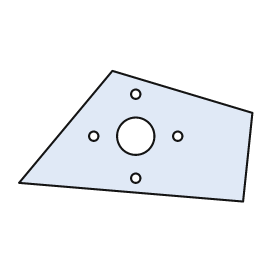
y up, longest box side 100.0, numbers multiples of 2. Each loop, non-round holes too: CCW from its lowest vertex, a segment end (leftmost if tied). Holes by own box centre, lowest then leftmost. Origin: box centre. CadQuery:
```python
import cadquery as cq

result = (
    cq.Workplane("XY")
    .moveTo(46.0, -28.0)
    .lineTo(50.0, 10.0)
    .lineTo(-10.0, 28.0)
    .lineTo(-50.0, -20.0)
    .close()
    .moveTo(0.0, -18.0)
    .circle(2.0)
    .moveTo(-18.0, 0.0)
    .circle(2.0)
    .moveTo(0.0, 0.0)
    .circle(8.0)
    .moveTo(18.0, 0.0)
    .circle(2.0)
    .moveTo(0.0, 18.0)
    .circle(2.0)
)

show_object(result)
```